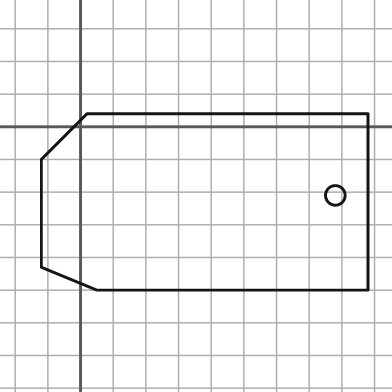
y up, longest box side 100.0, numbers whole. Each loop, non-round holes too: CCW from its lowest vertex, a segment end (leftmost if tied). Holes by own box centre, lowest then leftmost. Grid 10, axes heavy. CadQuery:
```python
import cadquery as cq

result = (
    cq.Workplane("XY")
    .moveTo(5.0, -50.0)
    .lineTo(88.0, -50.0)
    .lineTo(88.0, 4.0)
    .lineTo(2.0, 4.0)
    .lineTo(-12.0, -10.0)
    .lineTo(-12.0, -43.0)
    .close()
    .moveTo(78.0, -21.0)
    .circle(3.0)
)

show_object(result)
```